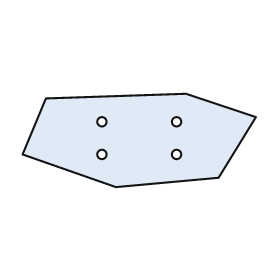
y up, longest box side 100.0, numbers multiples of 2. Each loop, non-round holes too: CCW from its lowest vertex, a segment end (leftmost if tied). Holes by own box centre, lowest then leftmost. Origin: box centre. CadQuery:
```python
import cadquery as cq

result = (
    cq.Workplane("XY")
    .moveTo(-10.0, -20.0)
    .lineTo(34.0, -16.0)
    .lineTo(50.0, 10.0)
    .lineTo(20.0, 20.0)
    .lineTo(-40.0, 18.0)
    .lineTo(-50.0, -6.0)
    .close()
    .moveTo(-16.0, -6.0)
    .circle(2.0)
    .moveTo(16.0, -6.0)
    .circle(2.0)
    .moveTo(-16.0, 8.0)
    .circle(2.0)
    .moveTo(16.0, 8.0)
    .circle(2.0)
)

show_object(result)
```